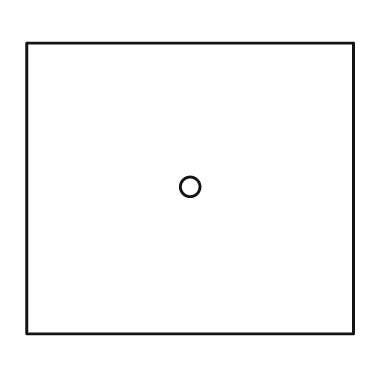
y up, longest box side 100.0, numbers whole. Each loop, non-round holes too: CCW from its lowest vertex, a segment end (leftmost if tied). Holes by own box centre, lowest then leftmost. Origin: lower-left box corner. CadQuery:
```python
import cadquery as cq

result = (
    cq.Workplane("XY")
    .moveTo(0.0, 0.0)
    .lineTo(100.0, 0.0)
    .lineTo(100.0, 89.0)
    .lineTo(0.0, 89.0)
    .close()
    .moveTo(50.0, 45.0)
    .circle(3.0)
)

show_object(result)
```